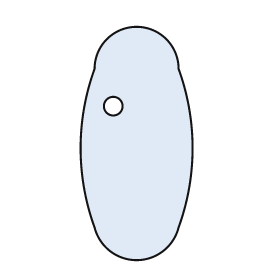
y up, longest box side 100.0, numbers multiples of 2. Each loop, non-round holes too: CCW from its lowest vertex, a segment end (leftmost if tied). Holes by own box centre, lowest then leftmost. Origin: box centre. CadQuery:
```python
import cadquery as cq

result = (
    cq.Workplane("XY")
    .moveTo(-18.0, -36.0)
    .threePointArc((0.0, -50.0), (18.0, -36.0))
    .threePointArc((24.0, -2.0), (18.0, 32.0))
    .threePointArc((0.0, 50.0), (-18.0, 32.0))
    .threePointArc((-24.0, -2.0), (-18.0, -36.0))
    .close()
    .moveTo(-10.0, 16.0)
    .circle(4.0)
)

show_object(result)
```